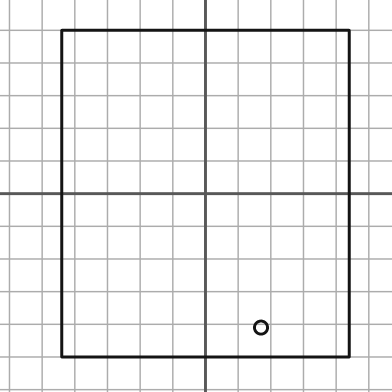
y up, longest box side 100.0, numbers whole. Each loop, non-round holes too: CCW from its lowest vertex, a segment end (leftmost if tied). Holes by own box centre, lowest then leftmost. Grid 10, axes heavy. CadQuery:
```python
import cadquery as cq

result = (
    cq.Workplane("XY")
    .moveTo(-44.0, -50.0)
    .lineTo(44.0, -50.0)
    .lineTo(44.0, 50.0)
    .lineTo(-44.0, 50.0)
    .close()
    .moveTo(17.0, -41.0)
    .circle(2.0)
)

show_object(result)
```